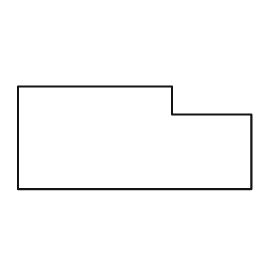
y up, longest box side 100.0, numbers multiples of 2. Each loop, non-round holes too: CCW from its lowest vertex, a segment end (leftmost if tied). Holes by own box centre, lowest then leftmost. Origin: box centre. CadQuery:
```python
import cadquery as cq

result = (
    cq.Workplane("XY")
    .moveTo(-50.0, -22.0)
    .lineTo(50.0, -22.0)
    .lineTo(50.0, 10.0)
    .lineTo(16.0, 10.0)
    .lineTo(16.0, 22.0)
    .lineTo(-50.0, 22.0)
    .close()
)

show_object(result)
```